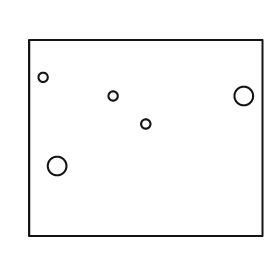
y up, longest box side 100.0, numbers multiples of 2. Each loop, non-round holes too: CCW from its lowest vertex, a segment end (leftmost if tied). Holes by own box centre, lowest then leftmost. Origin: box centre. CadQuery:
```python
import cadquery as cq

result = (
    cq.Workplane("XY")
    .moveTo(-50.0, -42.0)
    .lineTo(50.0, -42.0)
    .lineTo(50.0, 42.0)
    .lineTo(-50.0, 42.0)
    .close()
    .moveTo(-38.0, -12.0)
    .circle(4.0)
    .moveTo(0.0, 6.0)
    .circle(2.0)
    .moveTo(-14.0, 18.0)
    .circle(2.0)
    .moveTo(42.0, 18.0)
    .circle(4.0)
    .moveTo(-44.0, 26.0)
    .circle(2.0)
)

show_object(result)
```